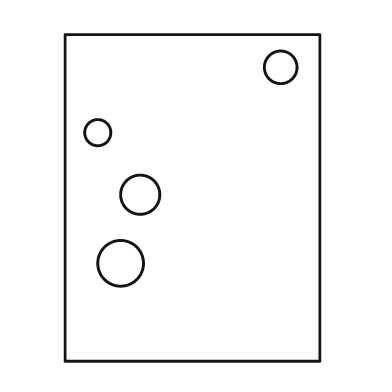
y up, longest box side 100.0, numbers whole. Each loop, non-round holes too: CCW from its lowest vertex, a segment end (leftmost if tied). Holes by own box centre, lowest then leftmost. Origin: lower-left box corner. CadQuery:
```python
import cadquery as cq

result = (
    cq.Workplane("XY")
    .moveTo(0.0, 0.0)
    .lineTo(78.0, 0.0)
    .lineTo(78.0, 100.0)
    .lineTo(0.0, 100.0)
    .close()
    .moveTo(17.0, 30.0)
    .circle(7.0)
    .moveTo(23.0, 51.0)
    .circle(6.0)
    .moveTo(10.0, 70.0)
    .circle(4.0)
    .moveTo(66.0, 90.0)
    .circle(5.0)
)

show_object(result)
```